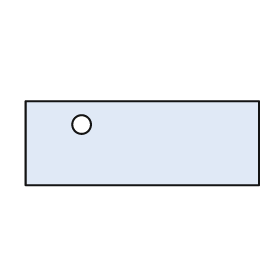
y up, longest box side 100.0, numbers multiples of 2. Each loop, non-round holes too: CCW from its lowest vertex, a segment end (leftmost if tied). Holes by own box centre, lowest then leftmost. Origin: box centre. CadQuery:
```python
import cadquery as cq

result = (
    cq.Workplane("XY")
    .moveTo(-50.0, -18.0)
    .lineTo(50.0, -18.0)
    .lineTo(50.0, 18.0)
    .lineTo(-50.0, 18.0)
    .close()
    .moveTo(-26.0, 8.0)
    .circle(4.0)
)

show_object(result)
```